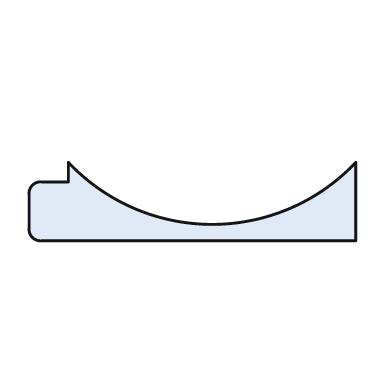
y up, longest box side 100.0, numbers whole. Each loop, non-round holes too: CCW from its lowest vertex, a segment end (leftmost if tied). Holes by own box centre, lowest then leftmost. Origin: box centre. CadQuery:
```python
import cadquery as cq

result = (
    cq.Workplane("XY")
    .moveTo(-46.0, -12.0)
    .lineTo(50.0, -12.0)
    .lineTo(50.0, 12.0)
    .threePointArc((6.0, -7.0), (-38.0, 12.0))
    .lineTo(-38.0, 6.0)
    .lineTo(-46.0, 6.0)
    .threePointArc((-49.0, 5.0), (-50.0, 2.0))
    .lineTo(-50.0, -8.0)
    .threePointArc((-49.0, -11.0), (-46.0, -12.0))
    .close()
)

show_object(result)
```